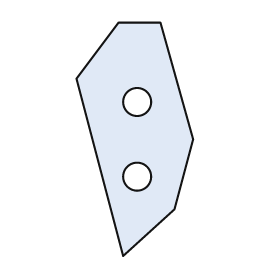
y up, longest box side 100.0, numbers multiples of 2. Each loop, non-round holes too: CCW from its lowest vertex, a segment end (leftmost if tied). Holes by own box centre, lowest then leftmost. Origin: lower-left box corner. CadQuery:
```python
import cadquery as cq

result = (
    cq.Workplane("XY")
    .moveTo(20.0, 0.0)
    .lineTo(42.0, 20.0)
    .lineTo(50.0, 50.0)
    .lineTo(36.0, 100.0)
    .lineTo(18.0, 100.0)
    .lineTo(0.0, 76.0)
    .close()
    .moveTo(26.0, 34.0)
    .circle(6.0)
    .moveTo(26.0, 66.0)
    .circle(6.0)
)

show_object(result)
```